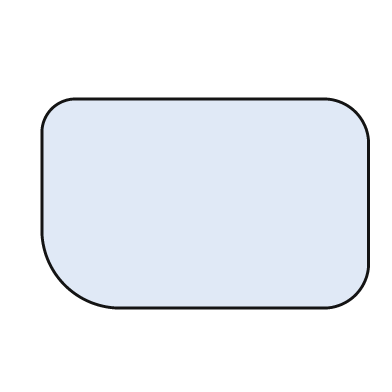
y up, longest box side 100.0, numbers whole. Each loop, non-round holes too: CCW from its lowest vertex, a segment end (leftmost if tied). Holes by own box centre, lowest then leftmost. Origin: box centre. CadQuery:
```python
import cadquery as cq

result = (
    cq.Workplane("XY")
    .moveTo(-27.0, -32.0)
    .lineTo(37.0, -32.0)
    .threePointArc((46.0, -28.0), (50.0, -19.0))
    .lineTo(50.0, 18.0)
    .threePointArc((46.0, 28.0), (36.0, 32.0))
    .lineTo(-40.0, 32.0)
    .threePointArc((-47.0, 29.0), (-50.0, 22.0))
    .lineTo(-50.0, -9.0)
    .threePointArc((-43.0, -25.0), (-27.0, -32.0))
    .close()
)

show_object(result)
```